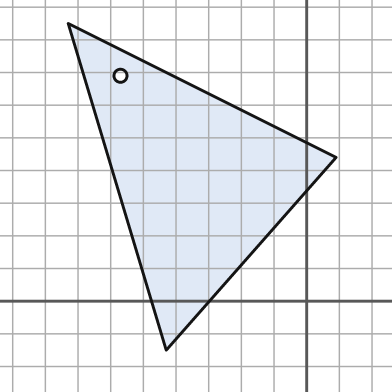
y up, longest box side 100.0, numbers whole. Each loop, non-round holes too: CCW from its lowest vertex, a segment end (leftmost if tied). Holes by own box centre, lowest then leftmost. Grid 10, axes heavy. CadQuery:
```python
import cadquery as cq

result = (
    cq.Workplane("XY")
    .moveTo(-43.0, -15.0)
    .lineTo(9.0, 44.0)
    .lineTo(-73.0, 85.0)
    .close()
    .moveTo(-57.0, 69.0)
    .circle(2.0)
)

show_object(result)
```